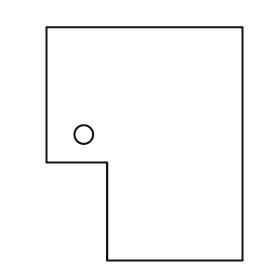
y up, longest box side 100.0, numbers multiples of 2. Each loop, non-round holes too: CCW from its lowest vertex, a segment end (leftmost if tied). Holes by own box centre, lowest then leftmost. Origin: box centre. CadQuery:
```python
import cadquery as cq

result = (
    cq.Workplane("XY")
    .moveTo(-16.0, -50.0)
    .lineTo(42.0, -50.0)
    .lineTo(42.0, 50.0)
    .lineTo(-42.0, 50.0)
    .lineTo(-42.0, -8.0)
    .lineTo(-16.0, -8.0)
    .close()
    .moveTo(-26.0, 4.0)
    .circle(4.0)
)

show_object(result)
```